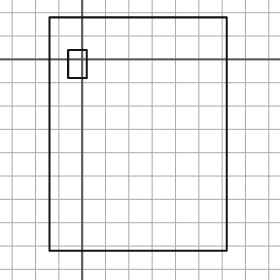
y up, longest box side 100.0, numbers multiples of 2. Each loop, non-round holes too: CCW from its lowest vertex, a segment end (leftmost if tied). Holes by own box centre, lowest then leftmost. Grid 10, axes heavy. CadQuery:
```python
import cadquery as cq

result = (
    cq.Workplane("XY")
    .moveTo(-14.0, -82.0)
    .lineTo(62.0, -82.0)
    .lineTo(62.0, 18.0)
    .lineTo(-14.0, 18.0)
    .close()
    .moveTo(-6.0, -8.0)
    .lineTo(2.0, -8.0)
    .lineTo(2.0, 4.0)
    .lineTo(-6.0, 4.0)
    .close()
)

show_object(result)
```